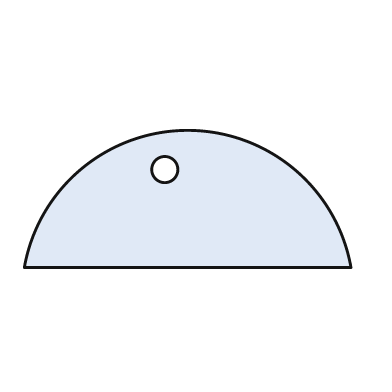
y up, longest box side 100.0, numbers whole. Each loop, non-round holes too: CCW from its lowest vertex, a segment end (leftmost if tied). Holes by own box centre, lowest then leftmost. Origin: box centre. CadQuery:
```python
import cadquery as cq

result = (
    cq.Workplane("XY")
    .moveTo(-50.0, -21.0)
    .lineTo(50.0, -21.0)
    .threePointArc((0.0, 21.0), (-50.0, -21.0))
    .close()
    .moveTo(-7.0, 9.0)
    .circle(4.0)
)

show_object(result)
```